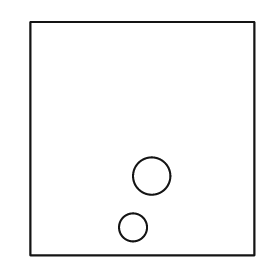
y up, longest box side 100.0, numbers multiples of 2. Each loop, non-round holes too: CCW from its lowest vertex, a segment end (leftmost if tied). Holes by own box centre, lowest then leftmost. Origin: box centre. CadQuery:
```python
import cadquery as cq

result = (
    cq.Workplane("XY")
    .moveTo(-48.0, -50.0)
    .lineTo(48.0, -50.0)
    .lineTo(48.0, 50.0)
    .lineTo(-48.0, 50.0)
    .close()
    .moveTo(-4.0, -38.0)
    .circle(6.0)
    .moveTo(4.0, -16.0)
    .circle(8.0)
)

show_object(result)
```